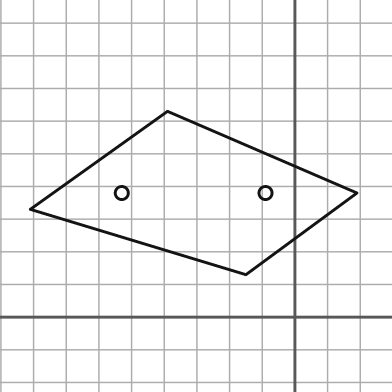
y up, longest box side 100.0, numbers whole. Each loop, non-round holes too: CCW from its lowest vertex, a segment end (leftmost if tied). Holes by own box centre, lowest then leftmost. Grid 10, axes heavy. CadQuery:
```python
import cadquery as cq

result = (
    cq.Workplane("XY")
    .moveTo(-15.0, 13.0)
    .lineTo(19.0, 38.0)
    .lineTo(-39.0, 63.0)
    .lineTo(-81.0, 33.0)
    .close()
    .moveTo(-53.0, 38.0)
    .circle(2.0)
    .moveTo(-9.0, 38.0)
    .circle(2.0)
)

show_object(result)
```